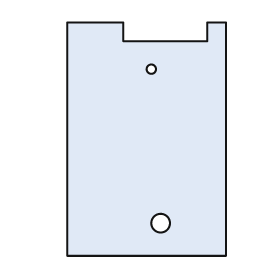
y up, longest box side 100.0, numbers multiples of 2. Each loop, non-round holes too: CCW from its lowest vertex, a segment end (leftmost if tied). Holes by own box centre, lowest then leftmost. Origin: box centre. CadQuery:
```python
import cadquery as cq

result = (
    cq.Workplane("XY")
    .moveTo(-34.0, -50.0)
    .lineTo(34.0, -50.0)
    .lineTo(34.0, 50.0)
    .lineTo(26.0, 50.0)
    .lineTo(26.0, 42.0)
    .lineTo(-10.0, 42.0)
    .lineTo(-10.0, 50.0)
    .lineTo(-34.0, 50.0)
    .close()
    .moveTo(6.0, -36.0)
    .circle(4.0)
    .moveTo(2.0, 30.0)
    .circle(2.0)
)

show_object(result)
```